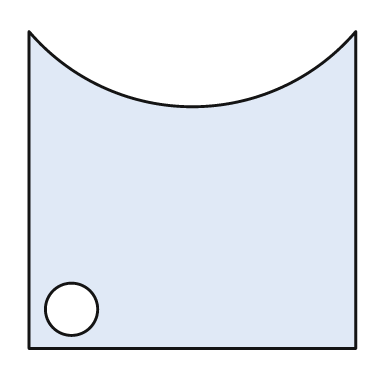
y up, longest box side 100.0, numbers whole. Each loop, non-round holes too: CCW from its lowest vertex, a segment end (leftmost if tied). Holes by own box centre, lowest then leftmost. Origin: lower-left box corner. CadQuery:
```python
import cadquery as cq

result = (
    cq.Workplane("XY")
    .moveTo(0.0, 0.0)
    .lineTo(100.0, 0.0)
    .lineTo(100.0, 97.0)
    .threePointArc((50.0, 74.0), (0.0, 97.0))
    .close()
    .moveTo(13.0, 12.0)
    .circle(8.0)
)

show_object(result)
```